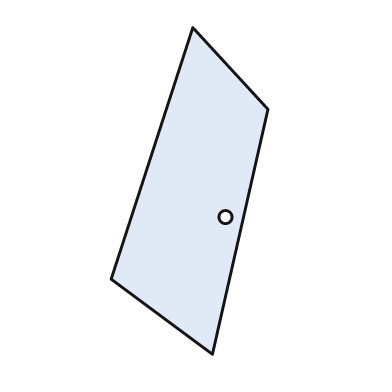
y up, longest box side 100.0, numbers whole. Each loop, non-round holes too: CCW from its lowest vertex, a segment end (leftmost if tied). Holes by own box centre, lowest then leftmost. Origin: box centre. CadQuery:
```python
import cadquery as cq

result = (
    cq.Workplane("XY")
    .moveTo(7.0, -50.0)
    .lineTo(24.0, 25.0)
    .lineTo(1.0, 50.0)
    .lineTo(-24.0, -27.0)
    .close()
    .moveTo(11.0, -8.0)
    .circle(2.0)
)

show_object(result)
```